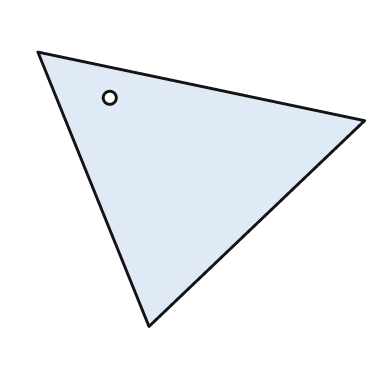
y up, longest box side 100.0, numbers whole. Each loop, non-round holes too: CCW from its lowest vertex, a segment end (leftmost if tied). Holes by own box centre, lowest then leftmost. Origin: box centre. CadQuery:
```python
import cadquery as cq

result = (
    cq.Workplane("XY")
    .moveTo(-16.0, -42.0)
    .lineTo(50.0, 21.0)
    .lineTo(-50.0, 42.0)
    .close()
    .moveTo(-28.0, 28.0)
    .circle(2.0)
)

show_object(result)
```